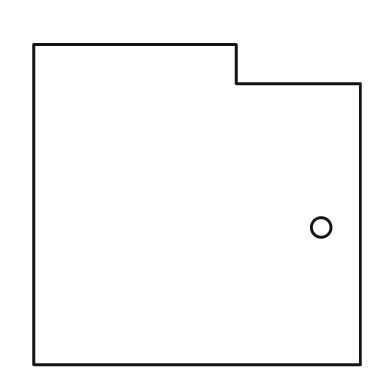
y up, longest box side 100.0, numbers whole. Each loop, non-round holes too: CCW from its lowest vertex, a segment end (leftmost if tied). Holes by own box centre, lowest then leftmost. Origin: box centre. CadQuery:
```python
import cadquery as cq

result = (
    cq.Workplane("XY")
    .moveTo(-50.0, -49.0)
    .lineTo(50.0, -49.0)
    .lineTo(50.0, 37.0)
    .lineTo(12.0, 37.0)
    .lineTo(12.0, 49.0)
    .lineTo(-50.0, 49.0)
    .close()
    .moveTo(38.0, -7.0)
    .circle(3.0)
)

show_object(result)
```